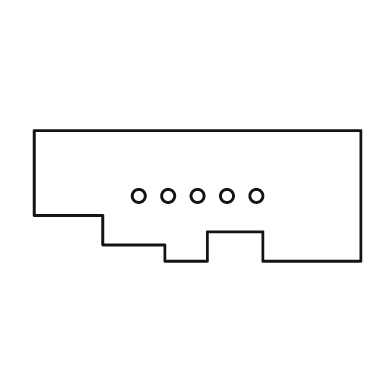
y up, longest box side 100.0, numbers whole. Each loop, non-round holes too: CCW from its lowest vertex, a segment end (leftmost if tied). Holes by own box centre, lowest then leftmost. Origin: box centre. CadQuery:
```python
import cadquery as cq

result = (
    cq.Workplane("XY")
    .moveTo(-10.0, -20.0)
    .lineTo(3.0, -20.0)
    .lineTo(3.0, -11.0)
    .lineTo(20.0, -11.0)
    .lineTo(20.0, -20.0)
    .lineTo(50.0, -20.0)
    .lineTo(50.0, 20.0)
    .lineTo(-50.0, 20.0)
    .lineTo(-50.0, -6.0)
    .lineTo(-29.0, -6.0)
    .lineTo(-29.0, -15.0)
    .lineTo(-10.0, -15.0)
    .close()
    .moveTo(-18.0, 0.0)
    .circle(2.0)
    .moveTo(-9.0, 0.0)
    .circle(2.0)
    .moveTo(0.0, 0.0)
    .circle(2.0)
    .moveTo(9.0, 0.0)
    .circle(2.0)
    .moveTo(18.0, 0.0)
    .circle(2.0)
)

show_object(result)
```